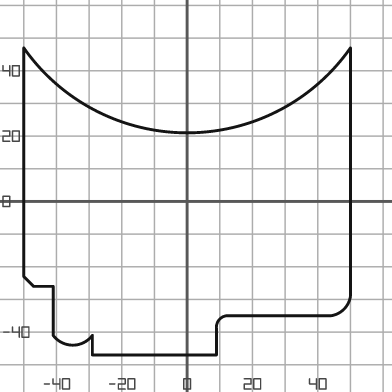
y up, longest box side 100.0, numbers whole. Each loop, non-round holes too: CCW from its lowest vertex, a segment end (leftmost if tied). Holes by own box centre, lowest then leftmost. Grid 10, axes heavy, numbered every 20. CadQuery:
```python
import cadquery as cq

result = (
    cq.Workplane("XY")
    .moveTo(-29.0, -47.0)
    .lineTo(9.0, -47.0)
    .lineTo(9.0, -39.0)
    .threePointArc((10.0, -36.0), (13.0, -35.0))
    .lineTo(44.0, -35.0)
    .threePointArc((48.0, -33.0), (50.0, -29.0))
    .lineTo(50.0, 47.0)
    .threePointArc((0.0, 21.0), (-50.0, 47.0))
    .lineTo(-50.0, -23.0)
    .lineTo(-47.0, -26.0)
    .lineTo(-41.0, -26.0)
    .lineTo(-41.0, -41.0)
    .threePointArc((-35.0, -44.0), (-29.0, -41.0))
    .close()
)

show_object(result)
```